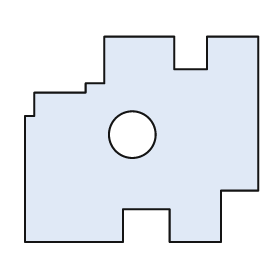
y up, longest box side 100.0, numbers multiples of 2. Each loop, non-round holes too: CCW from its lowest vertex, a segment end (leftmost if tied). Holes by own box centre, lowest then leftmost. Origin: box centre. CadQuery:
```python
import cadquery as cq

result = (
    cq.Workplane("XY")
    .moveTo(-50.0, -44.0)
    .lineTo(-8.0, -44.0)
    .lineTo(-8.0, -30.0)
    .lineTo(12.0, -30.0)
    .lineTo(12.0, -44.0)
    .lineTo(34.0, -44.0)
    .lineTo(34.0, -22.0)
    .lineTo(50.0, -22.0)
    .lineTo(50.0, 44.0)
    .lineTo(28.0, 44.0)
    .lineTo(28.0, 30.0)
    .lineTo(14.0, 30.0)
    .lineTo(14.0, 44.0)
    .lineTo(-16.0, 44.0)
    .lineTo(-16.0, 24.0)
    .lineTo(-24.0, 24.0)
    .lineTo(-24.0, 20.0)
    .lineTo(-46.0, 20.0)
    .lineTo(-46.0, 10.0)
    .lineTo(-50.0, 10.0)
    .close()
    .moveTo(-4.0, 2.0)
    .circle(10.0)
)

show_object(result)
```